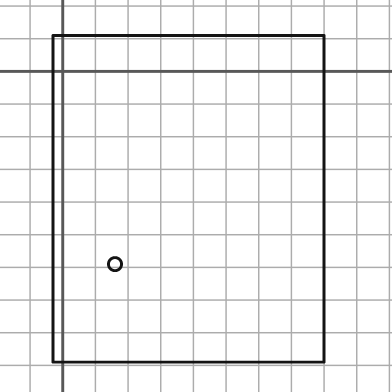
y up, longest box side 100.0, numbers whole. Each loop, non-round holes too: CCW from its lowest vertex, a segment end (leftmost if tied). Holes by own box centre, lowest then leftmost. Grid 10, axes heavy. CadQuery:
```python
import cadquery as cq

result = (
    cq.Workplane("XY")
    .moveTo(-3.0, -89.0)
    .lineTo(80.0, -89.0)
    .lineTo(80.0, 11.0)
    .lineTo(-3.0, 11.0)
    .close()
    .moveTo(16.0, -59.0)
    .circle(2.0)
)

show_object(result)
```